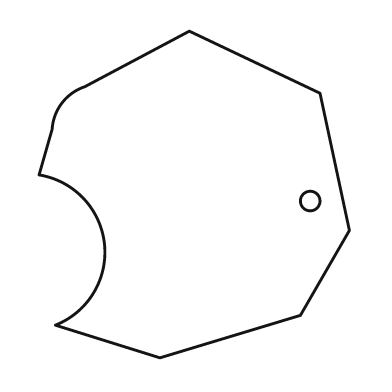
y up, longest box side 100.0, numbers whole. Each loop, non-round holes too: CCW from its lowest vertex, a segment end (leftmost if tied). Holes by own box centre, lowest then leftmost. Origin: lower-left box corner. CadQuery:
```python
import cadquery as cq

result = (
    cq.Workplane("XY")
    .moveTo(37.0, 0.0)
    .lineTo(80.0, 13.0)
    .lineTo(95.0, 39.0)
    .lineTo(86.0, 81.0)
    .lineTo(46.0, 100.0)
    .lineTo(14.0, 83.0)
    .threePointArc((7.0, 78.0), (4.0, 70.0))
    .lineTo(0.0, 56.0)
    .threePointArc((20.0, 35.0), (5.0, 10.0))
    .close()
    .moveTo(83.0, 48.0)
    .circle(3.0)
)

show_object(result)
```